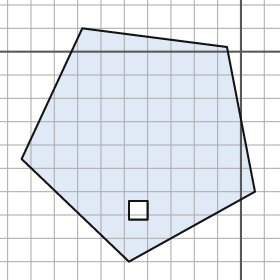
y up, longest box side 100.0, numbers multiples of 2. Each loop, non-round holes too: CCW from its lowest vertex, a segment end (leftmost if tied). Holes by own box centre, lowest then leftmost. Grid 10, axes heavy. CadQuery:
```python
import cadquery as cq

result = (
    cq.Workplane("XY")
    .moveTo(-48.0, -90.0)
    .lineTo(6.0, -60.0)
    .lineTo(-6.0, 2.0)
    .lineTo(-68.0, 10.0)
    .lineTo(-94.0, -46.0)
    .close()
    .moveTo(-48.0, -72.0)
    .lineTo(-40.0, -72.0)
    .lineTo(-40.0, -64.0)
    .lineTo(-48.0, -64.0)
    .close()
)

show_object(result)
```